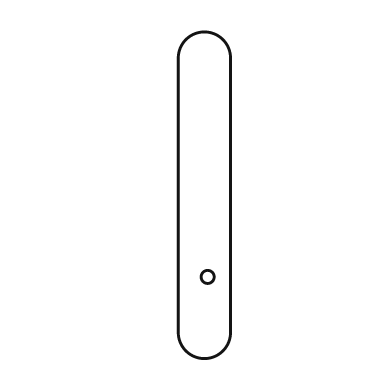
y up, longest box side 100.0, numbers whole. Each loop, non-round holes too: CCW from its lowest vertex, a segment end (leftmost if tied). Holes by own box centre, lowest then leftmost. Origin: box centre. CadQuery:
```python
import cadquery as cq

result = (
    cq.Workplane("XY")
    .moveTo(-8.0, -42.0)
    .threePointArc((0.0, -50.0), (8.0, -42.0))
    .lineTo(8.0, 42.0)
    .threePointArc((0.0, 50.0), (-8.0, 42.0))
    .close()
    .moveTo(1.0, -25.0)
    .circle(2.0)
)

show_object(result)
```